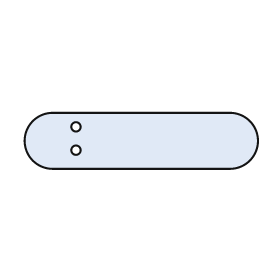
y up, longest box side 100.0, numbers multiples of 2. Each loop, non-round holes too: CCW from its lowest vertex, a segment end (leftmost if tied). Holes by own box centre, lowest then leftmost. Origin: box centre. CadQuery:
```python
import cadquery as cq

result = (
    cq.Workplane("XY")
    .moveTo(-38.0, -12.0)
    .lineTo(38.0, -12.0)
    .threePointArc((50.0, 0.0), (38.0, 12.0))
    .lineTo(-38.0, 12.0)
    .threePointArc((-50.0, 0.0), (-38.0, -12.0))
    .close()
    .moveTo(-28.0, -4.0)
    .circle(2.0)
    .moveTo(-28.0, 6.0)
    .circle(2.0)
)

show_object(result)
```